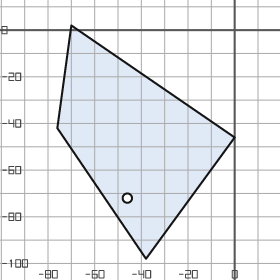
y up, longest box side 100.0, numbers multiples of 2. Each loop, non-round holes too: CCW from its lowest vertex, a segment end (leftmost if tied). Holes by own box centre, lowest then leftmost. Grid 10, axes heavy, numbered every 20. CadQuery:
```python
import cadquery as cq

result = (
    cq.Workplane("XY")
    .moveTo(-38.0, -98.0)
    .lineTo(0.0, -46.0)
    .lineTo(-70.0, 2.0)
    .lineTo(-76.0, -42.0)
    .close()
    .moveTo(-46.0, -72.0)
    .circle(2.0)
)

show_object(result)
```